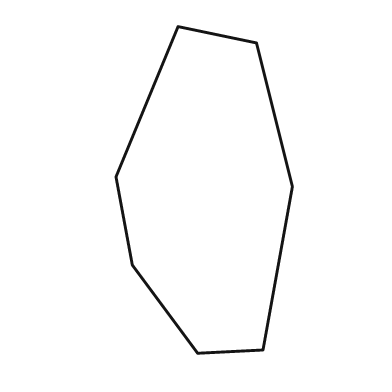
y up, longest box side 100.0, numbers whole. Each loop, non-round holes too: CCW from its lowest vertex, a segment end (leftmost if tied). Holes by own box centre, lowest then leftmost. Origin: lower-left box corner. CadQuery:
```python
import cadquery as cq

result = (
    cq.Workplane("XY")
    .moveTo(25.0, 0.0)
    .lineTo(45.0, 1.0)
    .lineTo(54.0, 51.0)
    .lineTo(43.0, 95.0)
    .lineTo(19.0, 100.0)
    .lineTo(0.0, 54.0)
    .lineTo(5.0, 27.0)
    .close()
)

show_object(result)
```